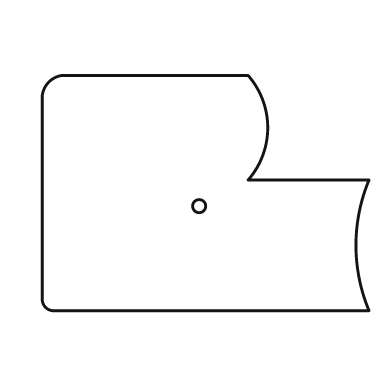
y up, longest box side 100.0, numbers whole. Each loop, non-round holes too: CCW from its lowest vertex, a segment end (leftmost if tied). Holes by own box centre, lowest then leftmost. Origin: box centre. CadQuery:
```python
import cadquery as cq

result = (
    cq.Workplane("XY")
    .moveTo(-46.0, -36.0)
    .lineTo(50.0, -36.0)
    .threePointArc((46.0, -16.0), (50.0, 4.0))
    .lineTo(13.0, 4.0)
    .threePointArc((19.0, 20.0), (13.0, 36.0))
    .lineTo(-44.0, 36.0)
    .threePointArc((-48.0, 34.0), (-50.0, 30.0))
    .lineTo(-50.0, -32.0)
    .threePointArc((-49.0, -35.0), (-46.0, -36.0))
    .close()
    .moveTo(-2.0, -4.0)
    .circle(2.0)
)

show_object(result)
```